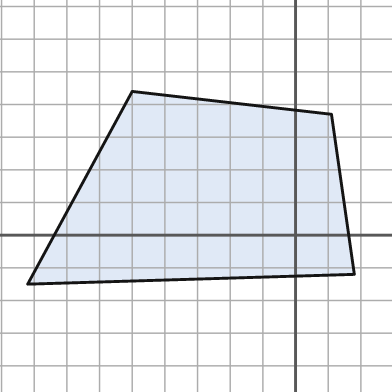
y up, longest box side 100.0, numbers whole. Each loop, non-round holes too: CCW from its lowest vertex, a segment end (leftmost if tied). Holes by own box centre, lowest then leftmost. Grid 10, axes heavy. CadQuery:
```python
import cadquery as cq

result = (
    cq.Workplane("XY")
    .moveTo(-82.0, -15.0)
    .lineTo(18.0, -12.0)
    .lineTo(11.0, 37.0)
    .lineTo(-50.0, 44.0)
    .close()
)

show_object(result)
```